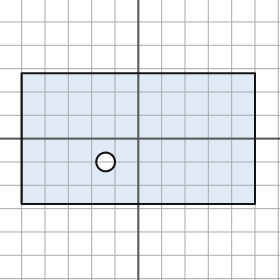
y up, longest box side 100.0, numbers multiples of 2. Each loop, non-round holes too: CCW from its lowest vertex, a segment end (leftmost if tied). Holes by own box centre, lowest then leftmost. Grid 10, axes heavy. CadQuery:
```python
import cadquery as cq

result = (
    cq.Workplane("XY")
    .moveTo(-50.0, -28.0)
    .lineTo(50.0, -28.0)
    .lineTo(50.0, 28.0)
    .lineTo(-50.0, 28.0)
    .close()
    .moveTo(-14.0, -10.0)
    .circle(4.0)
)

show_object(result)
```